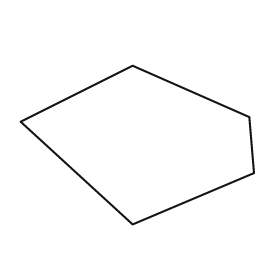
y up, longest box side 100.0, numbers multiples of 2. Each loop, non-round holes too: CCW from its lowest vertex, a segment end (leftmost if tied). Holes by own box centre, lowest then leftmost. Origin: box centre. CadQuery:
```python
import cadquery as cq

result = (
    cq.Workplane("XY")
    .moveTo(-2.0, -34.0)
    .lineTo(50.0, -12.0)
    .lineTo(48.0, 12.0)
    .lineTo(-2.0, 34.0)
    .lineTo(-50.0, 10.0)
    .close()
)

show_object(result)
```